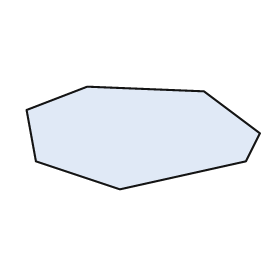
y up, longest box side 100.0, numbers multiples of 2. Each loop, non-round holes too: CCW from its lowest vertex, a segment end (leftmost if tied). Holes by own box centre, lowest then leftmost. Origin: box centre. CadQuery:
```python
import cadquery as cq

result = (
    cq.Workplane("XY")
    .moveTo(-10.0, -22.0)
    .lineTo(44.0, -10.0)
    .lineTo(50.0, 2.0)
    .lineTo(26.0, 20.0)
    .lineTo(-24.0, 22.0)
    .lineTo(-50.0, 12.0)
    .lineTo(-46.0, -10.0)
    .close()
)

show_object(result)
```